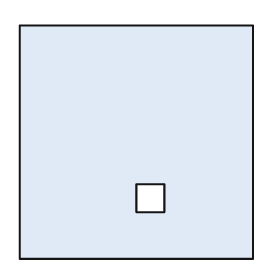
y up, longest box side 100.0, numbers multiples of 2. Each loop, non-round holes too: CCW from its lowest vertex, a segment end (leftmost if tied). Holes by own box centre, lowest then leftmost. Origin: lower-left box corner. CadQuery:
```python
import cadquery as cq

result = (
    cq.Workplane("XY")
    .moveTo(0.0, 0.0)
    .lineTo(100.0, 0.0)
    .lineTo(100.0, 100.0)
    .lineTo(0.0, 100.0)
    .close()
    .moveTo(50.0, 20.0)
    .lineTo(62.0, 20.0)
    .lineTo(62.0, 32.0)
    .lineTo(50.0, 32.0)
    .close()
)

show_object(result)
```